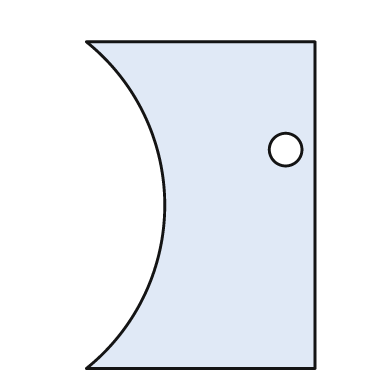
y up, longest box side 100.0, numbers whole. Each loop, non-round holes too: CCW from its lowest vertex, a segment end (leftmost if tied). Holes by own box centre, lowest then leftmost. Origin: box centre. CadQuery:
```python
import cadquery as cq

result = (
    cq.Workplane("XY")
    .moveTo(-35.0, -50.0)
    .lineTo(35.0, -50.0)
    .lineTo(35.0, 50.0)
    .lineTo(-35.0, 50.0)
    .threePointArc((-11.0, 0.0), (-35.0, -50.0))
    .close()
    .moveTo(26.0, 17.0)
    .circle(5.0)
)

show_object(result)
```